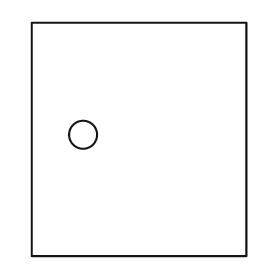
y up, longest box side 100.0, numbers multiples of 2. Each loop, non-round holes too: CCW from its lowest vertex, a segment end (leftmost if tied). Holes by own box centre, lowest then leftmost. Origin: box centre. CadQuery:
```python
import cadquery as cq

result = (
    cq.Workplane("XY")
    .moveTo(-46.0, -50.0)
    .lineTo(46.0, -50.0)
    .lineTo(46.0, 50.0)
    .lineTo(-46.0, 50.0)
    .close()
    .moveTo(-24.0, 2.0)
    .circle(6.0)
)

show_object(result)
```